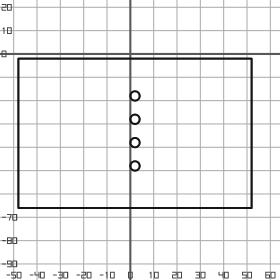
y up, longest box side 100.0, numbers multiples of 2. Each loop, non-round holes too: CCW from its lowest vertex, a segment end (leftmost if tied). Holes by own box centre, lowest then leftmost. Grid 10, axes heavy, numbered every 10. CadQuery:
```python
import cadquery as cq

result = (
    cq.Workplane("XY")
    .moveTo(-48.0, -66.0)
    .lineTo(52.0, -66.0)
    .lineTo(52.0, -2.0)
    .lineTo(-48.0, -2.0)
    .close()
    .moveTo(2.0, -48.0)
    .circle(2.0)
    .moveTo(2.0, -38.0)
    .circle(2.0)
    .moveTo(2.0, -28.0)
    .circle(2.0)
    .moveTo(2.0, -18.0)
    .circle(2.0)
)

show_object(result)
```